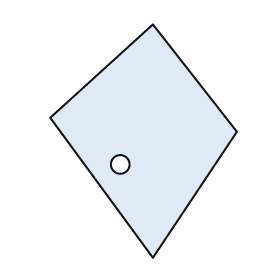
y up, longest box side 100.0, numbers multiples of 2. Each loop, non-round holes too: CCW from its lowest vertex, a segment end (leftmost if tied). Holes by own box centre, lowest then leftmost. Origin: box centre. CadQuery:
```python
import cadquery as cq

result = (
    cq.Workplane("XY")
    .moveTo(4.0, -50.0)
    .lineTo(40.0, 4.0)
    .lineTo(4.0, 50.0)
    .lineTo(-40.0, 10.0)
    .close()
    .moveTo(-10.0, -10.0)
    .circle(4.0)
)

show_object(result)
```